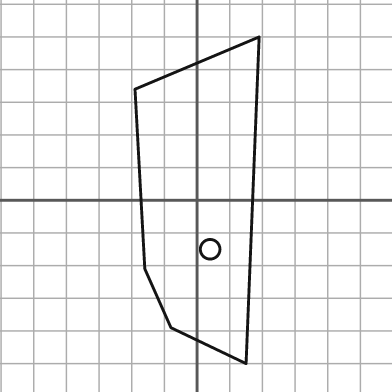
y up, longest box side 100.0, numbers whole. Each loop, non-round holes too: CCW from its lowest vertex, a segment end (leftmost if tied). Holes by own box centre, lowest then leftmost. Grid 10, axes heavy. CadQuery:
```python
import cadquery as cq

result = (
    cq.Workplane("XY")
    .moveTo(15.0, -50.0)
    .lineTo(19.0, 50.0)
    .lineTo(-19.0, 34.0)
    .lineTo(-16.0, -21.0)
    .lineTo(-8.0, -39.0)
    .close()
    .moveTo(4.0, -15.0)
    .circle(3.0)
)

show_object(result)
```